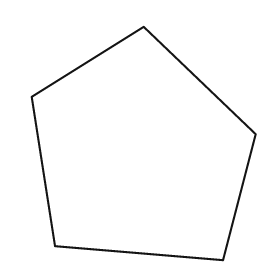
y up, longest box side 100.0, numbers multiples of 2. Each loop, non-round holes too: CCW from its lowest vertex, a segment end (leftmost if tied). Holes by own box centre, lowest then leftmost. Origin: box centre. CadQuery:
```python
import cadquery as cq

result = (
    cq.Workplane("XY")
    .moveTo(34.0, -50.0)
    .lineTo(48.0, 4.0)
    .lineTo(0.0, 50.0)
    .lineTo(-48.0, 20.0)
    .lineTo(-38.0, -44.0)
    .close()
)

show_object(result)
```